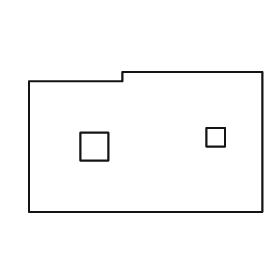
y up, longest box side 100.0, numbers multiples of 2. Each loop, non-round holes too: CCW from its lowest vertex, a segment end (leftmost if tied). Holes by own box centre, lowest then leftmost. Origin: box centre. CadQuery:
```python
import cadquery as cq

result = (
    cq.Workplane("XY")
    .moveTo(-50.0, -30.0)
    .lineTo(50.0, -30.0)
    .lineTo(50.0, 30.0)
    .lineTo(-10.0, 30.0)
    .lineTo(-10.0, 26.0)
    .lineTo(-50.0, 26.0)
    .close()
    .moveTo(-28.0, -8.0)
    .lineTo(-16.0, -8.0)
    .lineTo(-16.0, 4.0)
    .lineTo(-28.0, 4.0)
    .close()
    .moveTo(26.0, -2.0)
    .lineTo(34.0, -2.0)
    .lineTo(34.0, 6.0)
    .lineTo(26.0, 6.0)
    .close()
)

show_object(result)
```